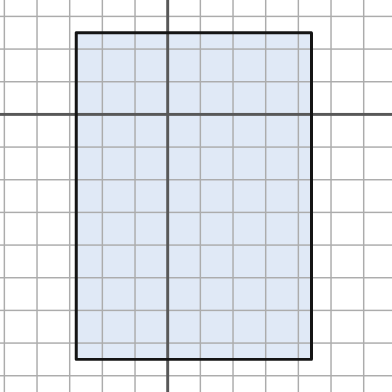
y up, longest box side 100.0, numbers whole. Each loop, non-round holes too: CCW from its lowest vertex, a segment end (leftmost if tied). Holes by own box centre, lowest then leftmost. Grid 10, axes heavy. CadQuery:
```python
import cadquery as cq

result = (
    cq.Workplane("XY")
    .moveTo(-28.0, -75.0)
    .lineTo(44.0, -75.0)
    .lineTo(44.0, 25.0)
    .lineTo(-28.0, 25.0)
    .close()
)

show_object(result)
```